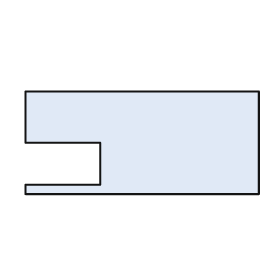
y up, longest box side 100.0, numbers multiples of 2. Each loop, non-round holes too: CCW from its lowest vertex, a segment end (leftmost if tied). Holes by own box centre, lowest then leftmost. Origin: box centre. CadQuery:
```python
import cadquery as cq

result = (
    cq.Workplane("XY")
    .moveTo(-50.0, -22.0)
    .lineTo(50.0, -22.0)
    .lineTo(50.0, 22.0)
    .lineTo(-50.0, 22.0)
    .lineTo(-50.0, 0.0)
    .lineTo(-18.0, 0.0)
    .lineTo(-18.0, -18.0)
    .lineTo(-50.0, -18.0)
    .close()
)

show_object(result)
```